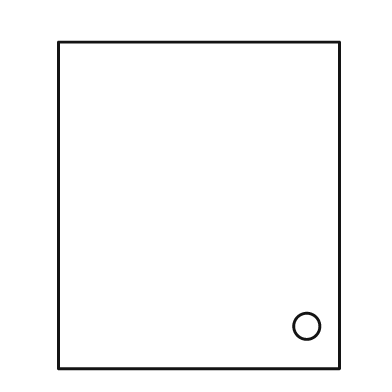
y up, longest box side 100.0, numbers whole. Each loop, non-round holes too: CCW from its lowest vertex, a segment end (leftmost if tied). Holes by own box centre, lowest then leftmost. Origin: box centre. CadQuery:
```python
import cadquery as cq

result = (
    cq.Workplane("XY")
    .moveTo(-43.0, -50.0)
    .lineTo(43.0, -50.0)
    .lineTo(43.0, 50.0)
    .lineTo(-43.0, 50.0)
    .close()
    .moveTo(33.0, -37.0)
    .circle(4.0)
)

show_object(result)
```